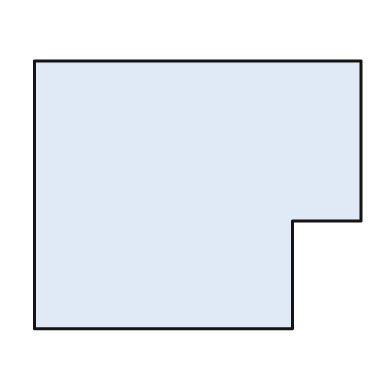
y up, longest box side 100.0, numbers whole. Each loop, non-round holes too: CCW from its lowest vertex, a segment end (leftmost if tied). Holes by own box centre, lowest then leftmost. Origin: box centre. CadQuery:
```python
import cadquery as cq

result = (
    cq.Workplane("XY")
    .moveTo(-50.0, -41.0)
    .lineTo(29.0, -41.0)
    .lineTo(29.0, -8.0)
    .lineTo(50.0, -8.0)
    .lineTo(50.0, 41.0)
    .lineTo(-50.0, 41.0)
    .close()
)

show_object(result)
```